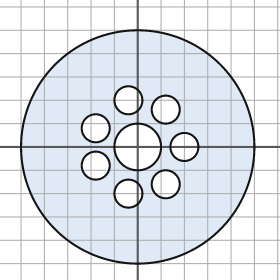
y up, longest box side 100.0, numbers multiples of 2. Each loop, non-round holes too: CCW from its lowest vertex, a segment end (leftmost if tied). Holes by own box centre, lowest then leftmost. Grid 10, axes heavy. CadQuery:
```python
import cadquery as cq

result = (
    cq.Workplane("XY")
    .moveTo(0.0, 0.0)
    .circle(50.0)
    .moveTo(-4.0, -20.0)
    .circle(6.0)
    .moveTo(12.0, -16.0)
    .circle(6.0)
    .moveTo(-18.0, -8.0)
    .circle(6.0)
    .moveTo(0.0, 0.0)
    .circle(10.0)
    .moveTo(20.0, 0.0)
    .circle(6.0)
    .moveTo(-18.0, 8.0)
    .circle(6.0)
    .moveTo(12.0, 16.0)
    .circle(6.0)
    .moveTo(-4.0, 20.0)
    .circle(6.0)
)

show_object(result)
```